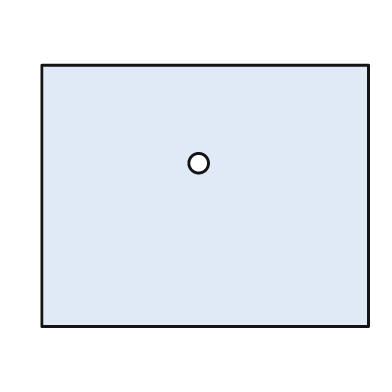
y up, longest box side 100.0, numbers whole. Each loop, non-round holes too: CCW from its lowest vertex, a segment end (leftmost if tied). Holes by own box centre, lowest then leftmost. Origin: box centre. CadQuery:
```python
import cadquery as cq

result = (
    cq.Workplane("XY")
    .moveTo(-50.0, -40.0)
    .lineTo(50.0, -40.0)
    .lineTo(50.0, 40.0)
    .lineTo(-50.0, 40.0)
    .close()
    .moveTo(-2.0, 10.0)
    .circle(3.0)
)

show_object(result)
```